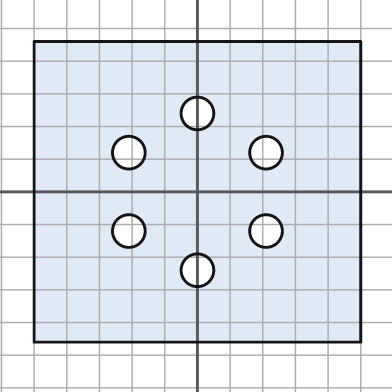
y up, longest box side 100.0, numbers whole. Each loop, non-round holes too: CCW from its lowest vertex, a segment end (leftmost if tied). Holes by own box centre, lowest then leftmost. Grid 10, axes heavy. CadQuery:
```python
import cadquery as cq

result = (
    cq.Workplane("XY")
    .moveTo(-50.0, -46.0)
    .lineTo(50.0, -46.0)
    .lineTo(50.0, 46.0)
    .lineTo(-50.0, 46.0)
    .close()
    .moveTo(0.0, -24.0)
    .circle(5.0)
    .moveTo(-21.0, -12.0)
    .circle(5.0)
    .moveTo(21.0, -12.0)
    .circle(5.0)
    .moveTo(-21.0, 12.0)
    .circle(5.0)
    .moveTo(21.0, 12.0)
    .circle(5.0)
    .moveTo(0.0, 24.0)
    .circle(5.0)
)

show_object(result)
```